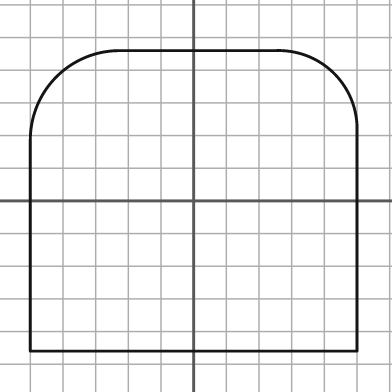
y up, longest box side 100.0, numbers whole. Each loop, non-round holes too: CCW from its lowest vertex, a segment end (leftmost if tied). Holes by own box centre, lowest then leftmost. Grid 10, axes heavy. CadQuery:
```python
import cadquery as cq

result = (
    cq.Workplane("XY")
    .moveTo(-50.0, -46.0)
    .lineTo(50.0, -46.0)
    .lineTo(50.0, 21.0)
    .threePointArc((43.0, 39.0), (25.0, 46.0))
    .lineTo(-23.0, 46.0)
    .threePointArc((-42.0, 38.0), (-50.0, 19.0))
    .close()
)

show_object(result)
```